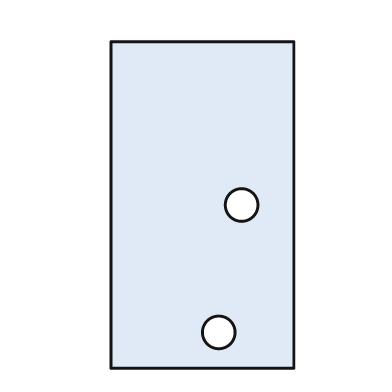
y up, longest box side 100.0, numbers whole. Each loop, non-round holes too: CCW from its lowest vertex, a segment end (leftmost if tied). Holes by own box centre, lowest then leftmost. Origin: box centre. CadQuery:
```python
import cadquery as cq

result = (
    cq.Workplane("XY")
    .moveTo(-28.0, -50.0)
    .lineTo(28.0, -50.0)
    .lineTo(28.0, 50.0)
    .lineTo(-28.0, 50.0)
    .close()
    .moveTo(5.0, -39.0)
    .circle(5.0)
    .moveTo(12.0, 0.0)
    .circle(5.0)
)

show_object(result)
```